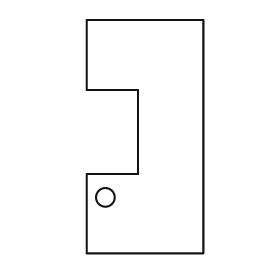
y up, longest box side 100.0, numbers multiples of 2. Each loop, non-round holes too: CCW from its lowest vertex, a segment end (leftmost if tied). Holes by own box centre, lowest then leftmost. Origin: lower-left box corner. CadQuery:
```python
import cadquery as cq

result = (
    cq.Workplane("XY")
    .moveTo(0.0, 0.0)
    .lineTo(50.0, 0.0)
    .lineTo(50.0, 100.0)
    .lineTo(0.0, 100.0)
    .lineTo(0.0, 70.0)
    .lineTo(22.0, 70.0)
    .lineTo(22.0, 34.0)
    .lineTo(0.0, 34.0)
    .close()
    .moveTo(8.0, 24.0)
    .circle(4.0)
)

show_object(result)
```